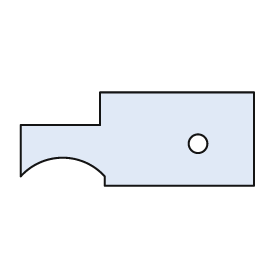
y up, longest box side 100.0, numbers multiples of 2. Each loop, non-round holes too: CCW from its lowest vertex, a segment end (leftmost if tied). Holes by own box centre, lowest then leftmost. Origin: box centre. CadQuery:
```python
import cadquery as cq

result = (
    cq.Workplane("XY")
    .moveTo(-14.0, -20.0)
    .lineTo(50.0, -20.0)
    .lineTo(50.0, 20.0)
    .lineTo(-16.0, 20.0)
    .lineTo(-16.0, 6.0)
    .lineTo(-50.0, 6.0)
    .lineTo(-50.0, -16.0)
    .threePointArc((-32.0, -8.0), (-14.0, -16.0))
    .close()
    .moveTo(26.0, -2.0)
    .circle(4.0)
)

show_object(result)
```